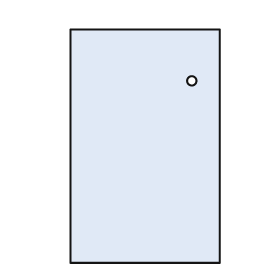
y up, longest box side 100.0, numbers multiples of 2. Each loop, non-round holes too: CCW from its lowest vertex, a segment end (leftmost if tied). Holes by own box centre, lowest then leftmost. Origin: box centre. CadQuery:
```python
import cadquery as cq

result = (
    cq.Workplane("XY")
    .moveTo(-32.0, -50.0)
    .lineTo(32.0, -50.0)
    .lineTo(32.0, 50.0)
    .lineTo(-32.0, 50.0)
    .close()
    .moveTo(20.0, 28.0)
    .circle(2.0)
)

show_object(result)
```